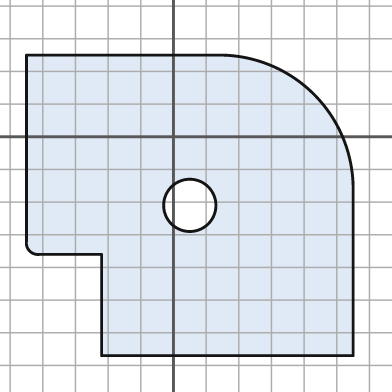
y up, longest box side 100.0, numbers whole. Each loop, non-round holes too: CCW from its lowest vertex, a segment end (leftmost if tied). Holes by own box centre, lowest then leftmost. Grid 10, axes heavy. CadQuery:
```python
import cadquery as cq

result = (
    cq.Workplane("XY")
    .moveTo(-22.0, -67.0)
    .lineTo(55.0, -67.0)
    .lineTo(55.0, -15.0)
    .threePointArc((43.0, 13.0), (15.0, 25.0))
    .lineTo(-45.0, 25.0)
    .lineTo(-45.0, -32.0)
    .threePointArc((-44.0, -35.0), (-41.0, -36.0))
    .lineTo(-22.0, -36.0)
    .close()
    .moveTo(5.0, -21.0)
    .circle(8.0)
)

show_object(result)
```